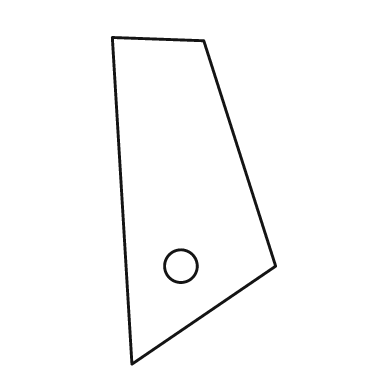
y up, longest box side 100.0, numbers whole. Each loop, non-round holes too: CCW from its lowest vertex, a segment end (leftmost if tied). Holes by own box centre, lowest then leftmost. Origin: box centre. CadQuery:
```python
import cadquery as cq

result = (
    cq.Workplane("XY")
    .moveTo(-19.0, -50.0)
    .lineTo(25.0, -20.0)
    .lineTo(3.0, 49.0)
    .lineTo(-25.0, 50.0)
    .close()
    .moveTo(-4.0, -20.0)
    .circle(5.0)
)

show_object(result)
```